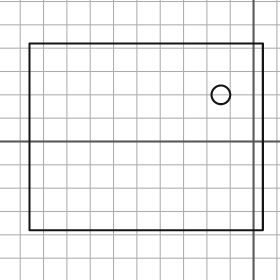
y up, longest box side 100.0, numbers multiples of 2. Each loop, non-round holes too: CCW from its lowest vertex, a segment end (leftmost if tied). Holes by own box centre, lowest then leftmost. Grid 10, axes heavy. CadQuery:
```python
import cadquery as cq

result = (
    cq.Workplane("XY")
    .moveTo(-96.0, -38.0)
    .lineTo(4.0, -38.0)
    .lineTo(4.0, 42.0)
    .lineTo(-96.0, 42.0)
    .close()
    .moveTo(-14.0, 20.0)
    .circle(4.0)
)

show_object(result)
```